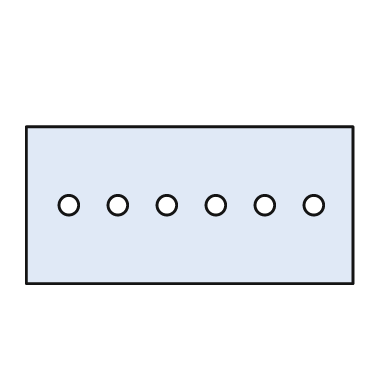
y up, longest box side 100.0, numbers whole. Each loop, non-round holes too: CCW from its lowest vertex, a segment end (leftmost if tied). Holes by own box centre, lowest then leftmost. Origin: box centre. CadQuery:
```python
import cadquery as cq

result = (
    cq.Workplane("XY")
    .moveTo(-50.0, -24.0)
    .lineTo(50.0, -24.0)
    .lineTo(50.0, 24.0)
    .lineTo(-50.0, 24.0)
    .close()
    .moveTo(-37.0, 0.0)
    .circle(3.0)
    .moveTo(-22.0, 0.0)
    .circle(3.0)
    .moveTo(-7.0, 0.0)
    .circle(3.0)
    .moveTo(8.0, 0.0)
    .circle(3.0)
    .moveTo(23.0, 0.0)
    .circle(3.0)
    .moveTo(38.0, 0.0)
    .circle(3.0)
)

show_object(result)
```